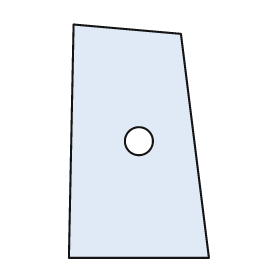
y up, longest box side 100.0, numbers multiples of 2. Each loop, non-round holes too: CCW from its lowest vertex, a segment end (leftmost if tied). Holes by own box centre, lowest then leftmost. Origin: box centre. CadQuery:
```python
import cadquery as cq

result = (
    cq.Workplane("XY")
    .moveTo(-30.0, -50.0)
    .lineTo(30.0, -50.0)
    .lineTo(18.0, 46.0)
    .lineTo(-28.0, 50.0)
    .close()
    .moveTo(0.0, 0.0)
    .circle(6.0)
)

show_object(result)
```